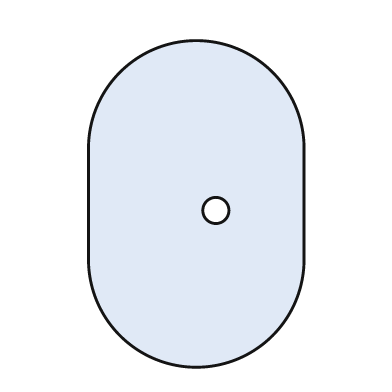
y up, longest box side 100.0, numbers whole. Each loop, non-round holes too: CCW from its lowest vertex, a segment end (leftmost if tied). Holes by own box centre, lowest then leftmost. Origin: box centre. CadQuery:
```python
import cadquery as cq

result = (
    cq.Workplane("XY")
    .moveTo(-33.0, -17.0)
    .threePointArc((0.0, -50.0), (33.0, -17.0))
    .lineTo(33.0, 17.0)
    .threePointArc((0.0, 50.0), (-33.0, 17.0))
    .close()
    .moveTo(6.0, -2.0)
    .circle(4.0)
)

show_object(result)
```